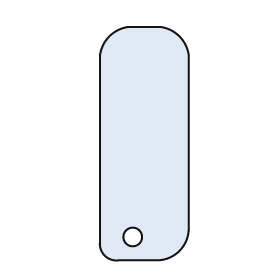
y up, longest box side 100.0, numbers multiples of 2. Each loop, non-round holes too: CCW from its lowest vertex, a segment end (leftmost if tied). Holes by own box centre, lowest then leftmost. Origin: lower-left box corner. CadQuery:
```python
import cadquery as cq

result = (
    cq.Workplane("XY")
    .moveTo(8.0, 0.0)
    .lineTo(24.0, 0.0)
    .threePointArc((34.0, 4.0), (38.0, 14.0))
    .lineTo(38.0, 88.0)
    .threePointArc((34.0, 96.0), (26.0, 100.0))
    .lineTo(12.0, 100.0)
    .threePointArc((4.0, 96.0), (0.0, 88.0))
    .lineTo(0.0, 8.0)
    .threePointArc((2.0, 2.0), (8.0, 0.0))
    .close()
    .moveTo(14.0, 10.0)
    .circle(4.0)
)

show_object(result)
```